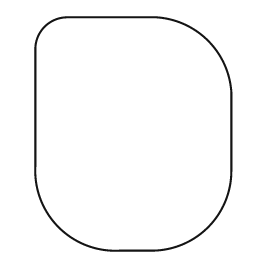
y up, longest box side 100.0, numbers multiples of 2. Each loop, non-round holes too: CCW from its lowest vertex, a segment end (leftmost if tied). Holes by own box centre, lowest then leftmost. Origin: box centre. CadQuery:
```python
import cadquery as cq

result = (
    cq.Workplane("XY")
    .moveTo(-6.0, -50.0)
    .lineTo(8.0, -50.0)
    .threePointArc((32.0, -40.0), (42.0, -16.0))
    .lineTo(42.0, 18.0)
    .threePointArc((32.0, 40.0), (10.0, 50.0))
    .lineTo(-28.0, 50.0)
    .threePointArc((-38.0, 46.0), (-42.0, 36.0))
    .lineTo(-42.0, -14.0)
    .threePointArc((-32.0, -40.0), (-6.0, -50.0))
    .close()
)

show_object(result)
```